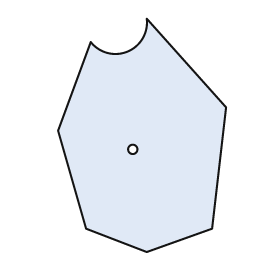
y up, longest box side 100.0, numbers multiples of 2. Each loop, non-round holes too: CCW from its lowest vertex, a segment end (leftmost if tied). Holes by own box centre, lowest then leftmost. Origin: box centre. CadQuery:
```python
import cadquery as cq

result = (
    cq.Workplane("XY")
    .moveTo(2.0, -50.0)
    .lineTo(30.0, -40.0)
    .lineTo(36.0, 12.0)
    .lineTo(2.0, 50.0)
    .threePointArc((-6.0, 36.0), (-22.0, 40.0))
    .lineTo(-36.0, 2.0)
    .lineTo(-24.0, -40.0)
    .close()
    .moveTo(-4.0, -6.0)
    .circle(2.0)
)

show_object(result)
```